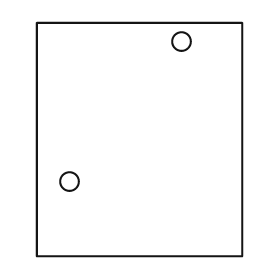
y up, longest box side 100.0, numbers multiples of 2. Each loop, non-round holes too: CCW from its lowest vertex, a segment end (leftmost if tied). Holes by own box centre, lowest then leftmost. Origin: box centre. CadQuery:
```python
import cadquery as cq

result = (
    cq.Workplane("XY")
    .moveTo(-44.0, -50.0)
    .lineTo(44.0, -50.0)
    .lineTo(44.0, 50.0)
    .lineTo(-44.0, 50.0)
    .close()
    .moveTo(-30.0, -18.0)
    .circle(4.0)
    .moveTo(18.0, 42.0)
    .circle(4.0)
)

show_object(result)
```